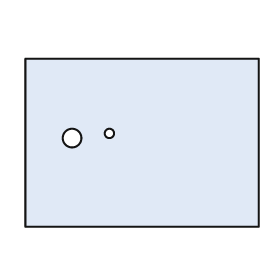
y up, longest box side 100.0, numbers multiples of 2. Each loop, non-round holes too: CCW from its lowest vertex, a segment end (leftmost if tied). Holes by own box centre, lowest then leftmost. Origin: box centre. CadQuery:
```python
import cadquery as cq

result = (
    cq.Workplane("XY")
    .moveTo(-50.0, -36.0)
    .lineTo(50.0, -36.0)
    .lineTo(50.0, 36.0)
    .lineTo(-50.0, 36.0)
    .close()
    .moveTo(-30.0, 2.0)
    .circle(4.0)
    .moveTo(-14.0, 4.0)
    .circle(2.0)
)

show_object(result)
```